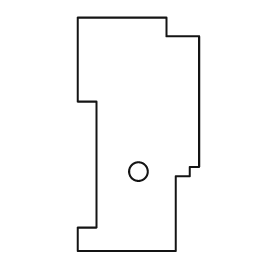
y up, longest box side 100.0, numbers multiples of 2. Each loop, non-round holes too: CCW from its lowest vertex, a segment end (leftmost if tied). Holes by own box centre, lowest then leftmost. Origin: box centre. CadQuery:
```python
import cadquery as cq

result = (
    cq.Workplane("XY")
    .moveTo(-26.0, -50.0)
    .lineTo(16.0, -50.0)
    .lineTo(16.0, -18.0)
    .lineTo(22.0, -18.0)
    .lineTo(22.0, -14.0)
    .lineTo(26.0, -14.0)
    .lineTo(26.0, 42.0)
    .lineTo(12.0, 42.0)
    .lineTo(12.0, 50.0)
    .lineTo(-26.0, 50.0)
    .lineTo(-26.0, 14.0)
    .lineTo(-18.0, 14.0)
    .lineTo(-18.0, -40.0)
    .lineTo(-26.0, -40.0)
    .close()
    .moveTo(0.0, -16.0)
    .circle(4.0)
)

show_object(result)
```